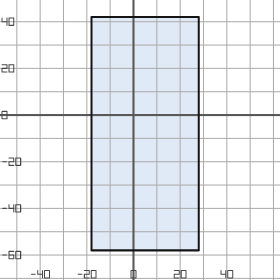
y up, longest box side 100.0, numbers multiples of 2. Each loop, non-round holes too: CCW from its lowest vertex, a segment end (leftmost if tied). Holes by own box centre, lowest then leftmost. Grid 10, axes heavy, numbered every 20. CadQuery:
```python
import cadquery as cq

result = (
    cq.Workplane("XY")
    .moveTo(-18.0, -58.0)
    .lineTo(28.0, -58.0)
    .lineTo(28.0, 42.0)
    .lineTo(-18.0, 42.0)
    .close()
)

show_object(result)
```